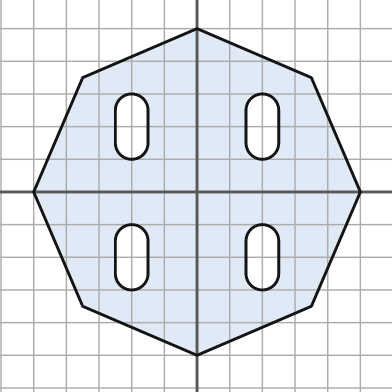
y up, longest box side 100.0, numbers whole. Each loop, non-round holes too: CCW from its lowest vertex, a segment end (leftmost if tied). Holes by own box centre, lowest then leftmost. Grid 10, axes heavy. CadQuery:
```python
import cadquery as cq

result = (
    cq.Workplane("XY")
    .moveTo(0.0, -50.0)
    .lineTo(35.0, -35.0)
    .lineTo(50.0, 0.0)
    .lineTo(35.0, 35.0)
    .lineTo(0.0, 50.0)
    .lineTo(-35.0, 35.0)
    .lineTo(-50.0, 0.0)
    .lineTo(-35.0, -35.0)
    .close()
    .moveTo(-25.0, -25.0)
    .threePointArc((-20.0, -30.0), (-15.0, -25.0))
    .lineTo(-15.0, -15.0)
    .threePointArc((-20.0, -10.0), (-25.0, -15.0))
    .close()
    .moveTo(15.0, -25.0)
    .threePointArc((20.0, -30.0), (25.0, -25.0))
    .lineTo(25.0, -15.0)
    .threePointArc((20.0, -10.0), (15.0, -15.0))
    .close()
    .moveTo(-25.0, 15.0)
    .threePointArc((-20.0, 10.0), (-15.0, 15.0))
    .lineTo(-15.0, 25.0)
    .threePointArc((-20.0, 30.0), (-25.0, 25.0))
    .close()
    .moveTo(15.0, 15.0)
    .threePointArc((20.0, 10.0), (25.0, 15.0))
    .lineTo(25.0, 25.0)
    .threePointArc((20.0, 30.0), (15.0, 25.0))
    .close()
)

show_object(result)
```